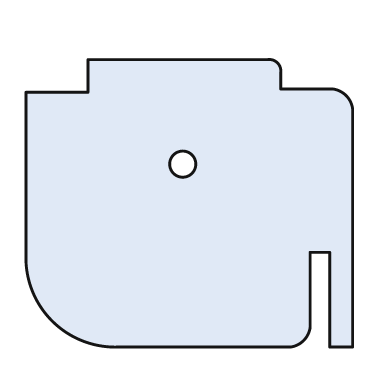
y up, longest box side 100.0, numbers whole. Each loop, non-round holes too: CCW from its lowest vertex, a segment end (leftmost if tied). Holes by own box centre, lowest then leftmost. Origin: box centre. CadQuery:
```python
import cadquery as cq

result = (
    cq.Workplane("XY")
    .moveTo(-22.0, -44.0)
    .lineTo(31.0, -44.0)
    .threePointArc((35.0, -42.0), (37.0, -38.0))
    .lineTo(37.0, -15.0)
    .lineTo(43.0, -15.0)
    .lineTo(43.0, -44.0)
    .lineTo(50.0, -44.0)
    .lineTo(50.0, 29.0)
    .threePointArc((48.0, 33.0), (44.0, 35.0))
    .lineTo(28.0, 35.0)
    .lineTo(28.0, 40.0)
    .threePointArc((27.0, 43.0), (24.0, 44.0))
    .lineTo(-31.0, 44.0)
    .lineTo(-31.0, 34.0)
    .lineTo(-50.0, 34.0)
    .lineTo(-50.0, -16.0)
    .threePointArc((-42.0, -36.0), (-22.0, -44.0))
    .close()
    .moveTo(-2.0, 12.0)
    .circle(4.0)
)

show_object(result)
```